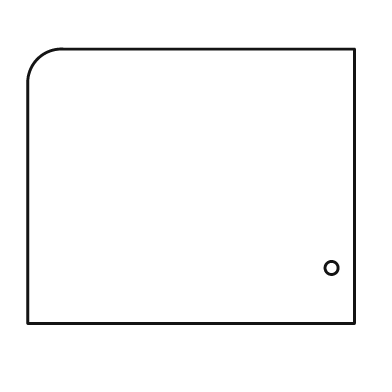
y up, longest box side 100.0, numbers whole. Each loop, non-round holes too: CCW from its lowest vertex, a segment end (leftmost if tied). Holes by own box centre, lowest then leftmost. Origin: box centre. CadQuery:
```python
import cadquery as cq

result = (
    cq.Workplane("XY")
    .moveTo(-50.0, -42.0)
    .lineTo(50.0, -42.0)
    .lineTo(50.0, 42.0)
    .lineTo(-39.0, 42.0)
    .threePointArc((-47.0, 39.0), (-50.0, 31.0))
    .close()
    .moveTo(43.0, -25.0)
    .circle(2.0)
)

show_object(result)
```